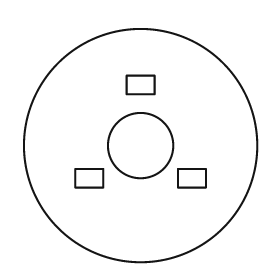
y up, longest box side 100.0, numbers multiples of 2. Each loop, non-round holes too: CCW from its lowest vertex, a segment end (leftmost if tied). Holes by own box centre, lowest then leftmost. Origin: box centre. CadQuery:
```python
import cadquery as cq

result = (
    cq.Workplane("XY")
    .moveTo(0.0, 0.0)
    .circle(50.0)
    .moveTo(-28.0, -18.0)
    .lineTo(-16.0, -18.0)
    .lineTo(-16.0, -10.0)
    .lineTo(-28.0, -10.0)
    .close()
    .moveTo(16.0, -18.0)
    .lineTo(28.0, -18.0)
    .lineTo(28.0, -10.0)
    .lineTo(16.0, -10.0)
    .close()
    .moveTo(0.0, 0.0)
    .circle(14.0)
    .moveTo(-6.0, 22.0)
    .lineTo(6.0, 22.0)
    .lineTo(6.0, 30.0)
    .lineTo(-6.0, 30.0)
    .close()
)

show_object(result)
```